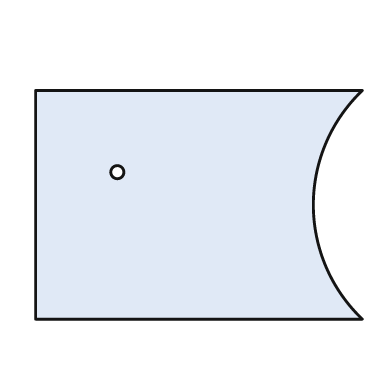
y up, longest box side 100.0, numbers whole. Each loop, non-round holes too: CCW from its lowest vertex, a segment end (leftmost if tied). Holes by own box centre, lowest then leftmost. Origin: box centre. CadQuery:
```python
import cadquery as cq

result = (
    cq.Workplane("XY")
    .moveTo(-50.0, -35.0)
    .lineTo(50.0, -35.0)
    .threePointArc((35.0, 0.0), (50.0, 35.0))
    .lineTo(-50.0, 35.0)
    .close()
    .moveTo(-25.0, 10.0)
    .circle(2.0)
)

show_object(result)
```